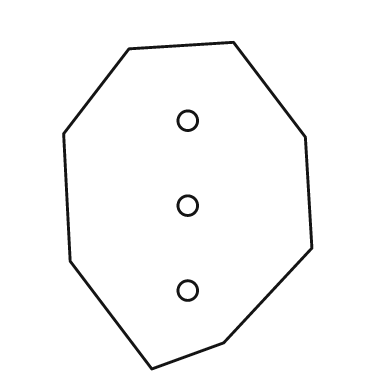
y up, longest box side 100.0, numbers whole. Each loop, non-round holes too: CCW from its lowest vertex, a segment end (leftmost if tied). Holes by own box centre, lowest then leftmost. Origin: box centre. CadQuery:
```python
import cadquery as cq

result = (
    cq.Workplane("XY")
    .moveTo(-11.0, -50.0)
    .lineTo(11.0, -42.0)
    .lineTo(38.0, -13.0)
    .lineTo(36.0, 21.0)
    .lineTo(14.0, 50.0)
    .lineTo(-18.0, 48.0)
    .lineTo(-38.0, 22.0)
    .lineTo(-36.0, -17.0)
    .close()
    .moveTo(0.0, -26.0)
    .circle(3.0)
    .moveTo(0.0, 0.0)
    .circle(3.0)
    .moveTo(0.0, 26.0)
    .circle(3.0)
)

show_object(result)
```